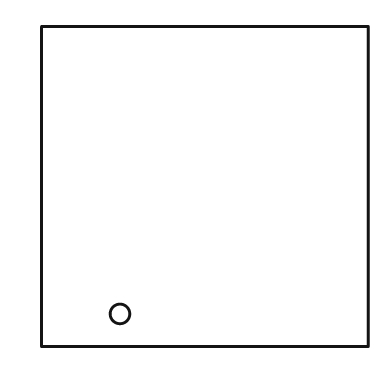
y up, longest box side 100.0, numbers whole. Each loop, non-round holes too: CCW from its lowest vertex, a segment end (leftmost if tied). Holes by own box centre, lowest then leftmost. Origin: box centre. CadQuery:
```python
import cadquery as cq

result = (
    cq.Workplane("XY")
    .moveTo(-50.0, -49.0)
    .lineTo(50.0, -49.0)
    .lineTo(50.0, 49.0)
    .lineTo(-50.0, 49.0)
    .close()
    .moveTo(-26.0, -39.0)
    .circle(3.0)
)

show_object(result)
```